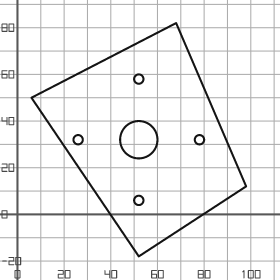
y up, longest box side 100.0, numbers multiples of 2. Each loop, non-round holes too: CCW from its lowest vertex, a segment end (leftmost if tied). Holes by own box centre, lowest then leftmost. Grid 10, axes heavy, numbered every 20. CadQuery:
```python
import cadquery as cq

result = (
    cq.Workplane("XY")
    .moveTo(52.0, -18.0)
    .lineTo(98.0, 12.0)
    .lineTo(68.0, 82.0)
    .lineTo(6.0, 50.0)
    .close()
    .moveTo(52.0, 6.0)
    .circle(2.0)
    .moveTo(26.0, 32.0)
    .circle(2.0)
    .moveTo(52.0, 32.0)
    .circle(8.0)
    .moveTo(78.0, 32.0)
    .circle(2.0)
    .moveTo(52.0, 58.0)
    .circle(2.0)
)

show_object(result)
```